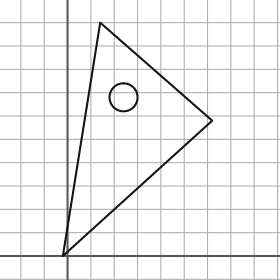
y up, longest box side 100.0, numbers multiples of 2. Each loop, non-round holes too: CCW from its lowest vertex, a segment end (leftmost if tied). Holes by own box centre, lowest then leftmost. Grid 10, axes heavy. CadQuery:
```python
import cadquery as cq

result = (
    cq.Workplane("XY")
    .moveTo(-2.0, 0.0)
    .lineTo(62.0, 58.0)
    .lineTo(14.0, 100.0)
    .close()
    .moveTo(24.0, 68.0)
    .circle(6.0)
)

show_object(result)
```